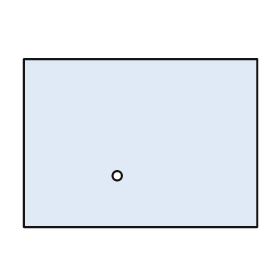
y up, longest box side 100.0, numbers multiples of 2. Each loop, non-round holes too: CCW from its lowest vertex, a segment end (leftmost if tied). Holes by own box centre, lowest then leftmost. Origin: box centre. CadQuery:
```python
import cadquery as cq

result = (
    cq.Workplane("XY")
    .moveTo(-50.0, -36.0)
    .lineTo(50.0, -36.0)
    .lineTo(50.0, 36.0)
    .lineTo(-50.0, 36.0)
    .close()
    .moveTo(-10.0, -14.0)
    .circle(2.0)
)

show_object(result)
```